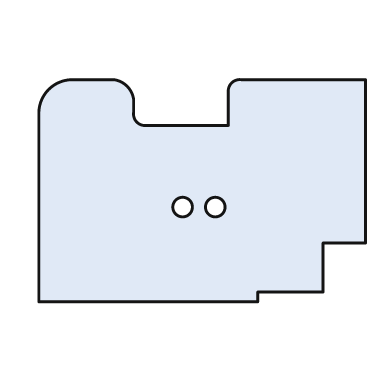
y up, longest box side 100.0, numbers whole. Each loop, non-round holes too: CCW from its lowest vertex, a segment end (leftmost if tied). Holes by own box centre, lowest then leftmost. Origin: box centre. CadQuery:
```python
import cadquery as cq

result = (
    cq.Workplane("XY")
    .moveTo(-50.0, -34.0)
    .lineTo(17.0, -34.0)
    .lineTo(17.0, -31.0)
    .lineTo(37.0, -31.0)
    .lineTo(37.0, -16.0)
    .lineTo(50.0, -16.0)
    .lineTo(50.0, 34.0)
    .lineTo(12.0, 34.0)
    .threePointArc((9.0, 33.0), (8.0, 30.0))
    .lineTo(8.0, 20.0)
    .lineTo(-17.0, 20.0)
    .threePointArc((-20.0, 21.0), (-21.0, 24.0))
    .lineTo(-21.0, 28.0)
    .threePointArc((-23.0, 32.0), (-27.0, 34.0))
    .lineTo(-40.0, 34.0)
    .threePointArc((-47.0, 31.0), (-50.0, 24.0))
    .close()
    .moveTo(-6.0, -5.0)
    .circle(3.0)
    .moveTo(4.0, -5.0)
    .circle(3.0)
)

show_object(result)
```